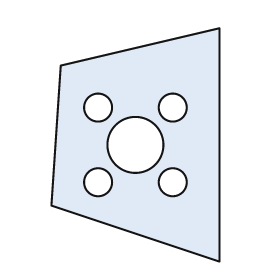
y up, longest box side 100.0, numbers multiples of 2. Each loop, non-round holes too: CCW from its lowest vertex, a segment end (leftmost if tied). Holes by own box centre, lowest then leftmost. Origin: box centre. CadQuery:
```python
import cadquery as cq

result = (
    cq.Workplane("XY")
    .moveTo(36.0, -50.0)
    .lineTo(36.0, 50.0)
    .lineTo(-32.0, 34.0)
    .lineTo(-36.0, -26.0)
    .close()
    .moveTo(-16.0, -16.0)
    .circle(6.0)
    .moveTo(16.0, -16.0)
    .circle(6.0)
    .moveTo(0.0, 0.0)
    .circle(12.0)
    .moveTo(-16.0, 16.0)
    .circle(6.0)
    .moveTo(16.0, 16.0)
    .circle(6.0)
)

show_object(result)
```